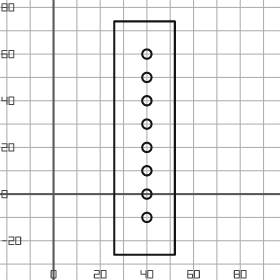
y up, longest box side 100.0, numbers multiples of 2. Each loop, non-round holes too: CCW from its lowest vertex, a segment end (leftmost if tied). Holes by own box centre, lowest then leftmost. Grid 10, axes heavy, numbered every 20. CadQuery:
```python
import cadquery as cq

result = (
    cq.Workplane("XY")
    .moveTo(26.0, -26.0)
    .lineTo(52.0, -26.0)
    .lineTo(52.0, 74.0)
    .lineTo(26.0, 74.0)
    .close()
    .moveTo(40.0, -10.0)
    .circle(2.0)
    .moveTo(40.0, 0.0)
    .circle(2.0)
    .moveTo(40.0, 10.0)
    .circle(2.0)
    .moveTo(40.0, 20.0)
    .circle(2.0)
    .moveTo(40.0, 30.0)
    .circle(2.0)
    .moveTo(40.0, 40.0)
    .circle(2.0)
    .moveTo(40.0, 50.0)
    .circle(2.0)
    .moveTo(40.0, 60.0)
    .circle(2.0)
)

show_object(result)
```